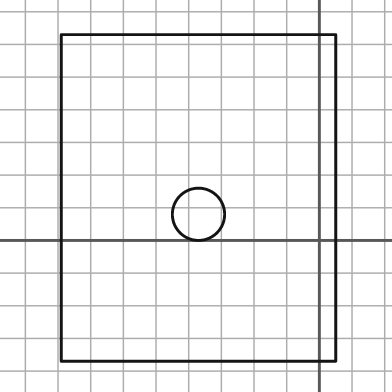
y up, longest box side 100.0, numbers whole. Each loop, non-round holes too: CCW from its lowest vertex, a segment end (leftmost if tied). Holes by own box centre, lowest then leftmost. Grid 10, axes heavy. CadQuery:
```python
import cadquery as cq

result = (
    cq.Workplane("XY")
    .moveTo(-79.0, -37.0)
    .lineTo(5.0, -37.0)
    .lineTo(5.0, 63.0)
    .lineTo(-79.0, 63.0)
    .close()
    .moveTo(-37.0, 8.0)
    .circle(8.0)
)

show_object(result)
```